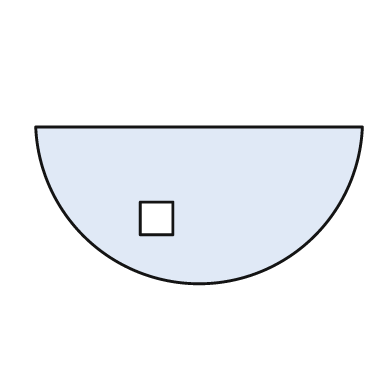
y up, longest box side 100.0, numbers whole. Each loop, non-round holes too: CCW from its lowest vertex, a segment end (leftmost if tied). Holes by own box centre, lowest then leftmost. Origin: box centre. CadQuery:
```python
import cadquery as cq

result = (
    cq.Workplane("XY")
    .moveTo(-50.0, 24.0)
    .threePointArc((0.0, -24.0), (50.0, 24.0))
    .close()
    .moveTo(-18.0, -9.0)
    .lineTo(-8.0, -9.0)
    .lineTo(-8.0, 1.0)
    .lineTo(-18.0, 1.0)
    .close()
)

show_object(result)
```